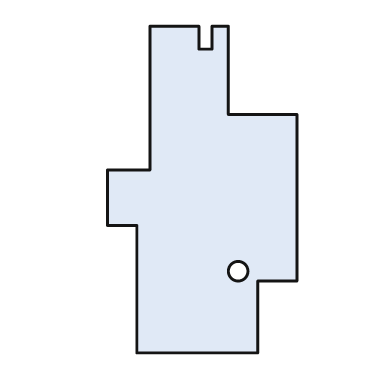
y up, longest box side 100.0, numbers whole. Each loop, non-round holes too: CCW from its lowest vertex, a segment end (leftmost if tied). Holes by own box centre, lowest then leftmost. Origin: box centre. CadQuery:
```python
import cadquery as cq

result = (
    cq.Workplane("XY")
    .moveTo(-20.0, -50.0)
    .lineTo(17.0, -50.0)
    .lineTo(17.0, -28.0)
    .lineTo(29.0, -28.0)
    .lineTo(29.0, 23.0)
    .lineTo(8.0, 23.0)
    .lineTo(8.0, 50.0)
    .lineTo(3.0, 50.0)
    .lineTo(3.0, 43.0)
    .lineTo(-1.0, 43.0)
    .lineTo(-1.0, 50.0)
    .lineTo(-16.0, 50.0)
    .lineTo(-16.0, 6.0)
    .lineTo(-29.0, 6.0)
    .lineTo(-29.0, -11.0)
    .lineTo(-20.0, -11.0)
    .close()
    .moveTo(11.0, -25.0)
    .circle(3.0)
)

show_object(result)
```